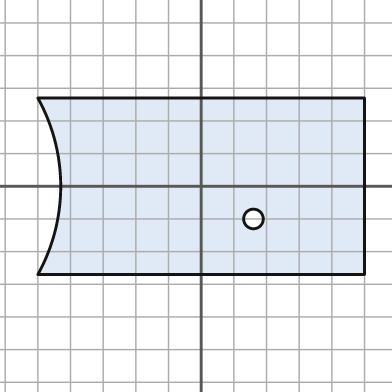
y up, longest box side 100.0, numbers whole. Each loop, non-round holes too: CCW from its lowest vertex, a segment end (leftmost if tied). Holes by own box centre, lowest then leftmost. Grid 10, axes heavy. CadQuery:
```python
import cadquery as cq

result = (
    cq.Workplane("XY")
    .moveTo(-50.0, -27.0)
    .lineTo(50.0, -27.0)
    .lineTo(50.0, 27.0)
    .lineTo(-50.0, 27.0)
    .threePointArc((-43.0, 0.0), (-50.0, -27.0))
    .close()
    .moveTo(16.0, -10.0)
    .circle(3.0)
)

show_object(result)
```